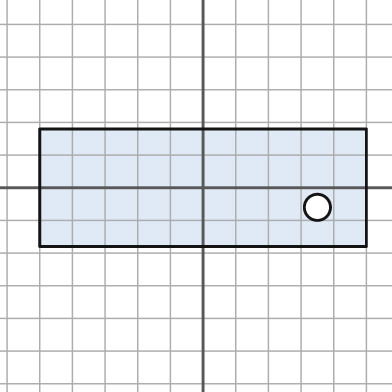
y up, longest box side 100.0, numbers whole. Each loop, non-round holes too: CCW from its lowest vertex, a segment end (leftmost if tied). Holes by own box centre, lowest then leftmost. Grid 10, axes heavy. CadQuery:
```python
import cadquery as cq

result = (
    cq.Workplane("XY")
    .moveTo(-50.0, -18.0)
    .lineTo(50.0, -18.0)
    .lineTo(50.0, 18.0)
    .lineTo(-50.0, 18.0)
    .close()
    .moveTo(35.0, -6.0)
    .circle(4.0)
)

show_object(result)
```